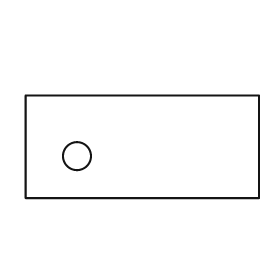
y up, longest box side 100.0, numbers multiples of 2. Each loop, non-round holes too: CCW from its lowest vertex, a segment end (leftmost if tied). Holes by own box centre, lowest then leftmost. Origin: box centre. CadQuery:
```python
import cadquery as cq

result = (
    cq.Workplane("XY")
    .moveTo(-50.0, -22.0)
    .lineTo(50.0, -22.0)
    .lineTo(50.0, 22.0)
    .lineTo(-50.0, 22.0)
    .close()
    .moveTo(-28.0, -4.0)
    .circle(6.0)
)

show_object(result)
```